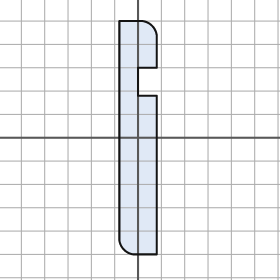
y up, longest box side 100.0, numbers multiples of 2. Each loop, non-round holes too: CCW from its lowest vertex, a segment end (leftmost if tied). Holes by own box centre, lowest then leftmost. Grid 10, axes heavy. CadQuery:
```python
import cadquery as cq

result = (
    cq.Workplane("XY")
    .moveTo(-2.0, -50.0)
    .lineTo(8.0, -50.0)
    .lineTo(8.0, 18.0)
    .lineTo(0.0, 18.0)
    .lineTo(0.0, 30.0)
    .lineTo(8.0, 30.0)
    .lineTo(8.0, 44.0)
    .threePointArc((6.0, 48.0), (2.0, 50.0))
    .lineTo(-8.0, 50.0)
    .lineTo(-8.0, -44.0)
    .threePointArc((-6.0, -48.0), (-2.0, -50.0))
    .close()
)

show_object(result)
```